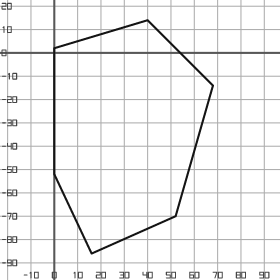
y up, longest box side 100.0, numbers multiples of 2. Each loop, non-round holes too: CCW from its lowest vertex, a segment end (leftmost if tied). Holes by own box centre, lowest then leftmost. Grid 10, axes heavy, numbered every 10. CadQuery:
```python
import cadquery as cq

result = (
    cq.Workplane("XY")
    .moveTo(16.0, -86.0)
    .lineTo(52.0, -70.0)
    .lineTo(68.0, -14.0)
    .lineTo(40.0, 14.0)
    .lineTo(0.0, 2.0)
    .lineTo(0.0, -52.0)
    .close()
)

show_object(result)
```